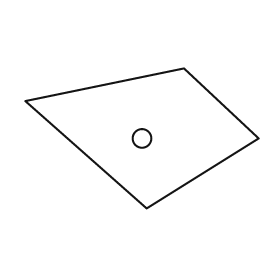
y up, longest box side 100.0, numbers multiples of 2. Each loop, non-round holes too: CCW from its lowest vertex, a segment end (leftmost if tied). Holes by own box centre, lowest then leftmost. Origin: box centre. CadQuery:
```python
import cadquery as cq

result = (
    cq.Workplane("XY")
    .moveTo(2.0, -30.0)
    .lineTo(50.0, 0.0)
    .lineTo(18.0, 30.0)
    .lineTo(-50.0, 16.0)
    .close()
    .moveTo(0.0, 0.0)
    .circle(4.0)
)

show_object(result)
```